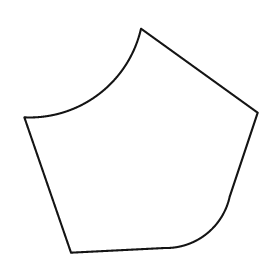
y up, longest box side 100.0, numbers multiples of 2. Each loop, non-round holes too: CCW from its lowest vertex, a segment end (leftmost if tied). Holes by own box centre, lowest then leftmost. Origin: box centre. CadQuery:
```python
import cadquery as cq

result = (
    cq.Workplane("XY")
    .moveTo(-30.0, -48.0)
    .lineTo(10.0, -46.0)
    .threePointArc((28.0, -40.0), (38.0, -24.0))
    .lineTo(50.0, 12.0)
    .lineTo(0.0, 48.0)
    .threePointArc((-18.0, 20.0), (-50.0, 10.0))
    .close()
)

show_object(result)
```